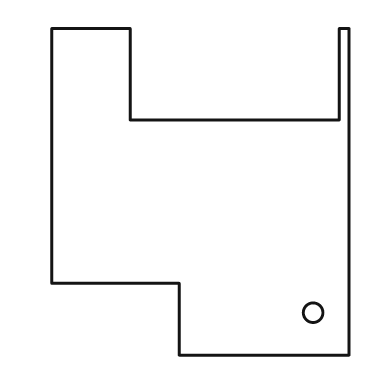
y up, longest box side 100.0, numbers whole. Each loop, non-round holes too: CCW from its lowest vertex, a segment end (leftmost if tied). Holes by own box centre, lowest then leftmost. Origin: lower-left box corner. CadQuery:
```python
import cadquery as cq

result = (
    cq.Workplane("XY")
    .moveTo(39.0, 0.0)
    .lineTo(91.0, 0.0)
    .lineTo(91.0, 100.0)
    .lineTo(88.0, 100.0)
    .lineTo(88.0, 72.0)
    .lineTo(24.0, 72.0)
    .lineTo(24.0, 100.0)
    .lineTo(0.0, 100.0)
    .lineTo(0.0, 22.0)
    .lineTo(39.0, 22.0)
    .close()
    .moveTo(80.0, 13.0)
    .circle(3.0)
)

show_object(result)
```